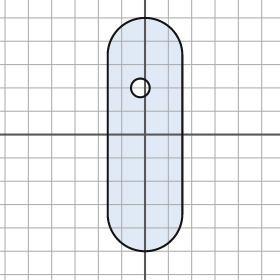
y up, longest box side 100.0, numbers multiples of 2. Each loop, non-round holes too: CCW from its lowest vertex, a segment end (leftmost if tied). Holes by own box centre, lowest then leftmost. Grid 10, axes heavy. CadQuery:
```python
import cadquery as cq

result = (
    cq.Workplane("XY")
    .moveTo(-16.0, -34.0)
    .threePointArc((0.0, -50.0), (16.0, -34.0))
    .lineTo(16.0, 34.0)
    .threePointArc((0.0, 50.0), (-16.0, 34.0))
    .close()
    .moveTo(-2.0, 20.0)
    .circle(4.0)
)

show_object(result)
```